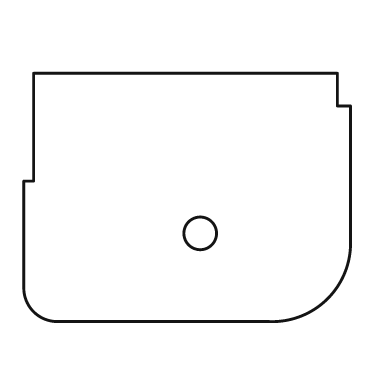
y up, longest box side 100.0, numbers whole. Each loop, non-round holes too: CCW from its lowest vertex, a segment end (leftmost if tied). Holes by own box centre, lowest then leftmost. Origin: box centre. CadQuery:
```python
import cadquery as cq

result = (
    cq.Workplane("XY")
    .moveTo(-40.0, -38.0)
    .lineTo(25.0, -38.0)
    .threePointArc((43.0, -31.0), (50.0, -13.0))
    .lineTo(50.0, 28.0)
    .lineTo(46.0, 28.0)
    .lineTo(46.0, 38.0)
    .lineTo(-47.0, 38.0)
    .lineTo(-47.0, 5.0)
    .lineTo(-50.0, 5.0)
    .lineTo(-50.0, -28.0)
    .threePointArc((-47.0, -35.0), (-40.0, -38.0))
    .close()
    .moveTo(4.0, -11.0)
    .circle(5.0)
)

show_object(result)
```